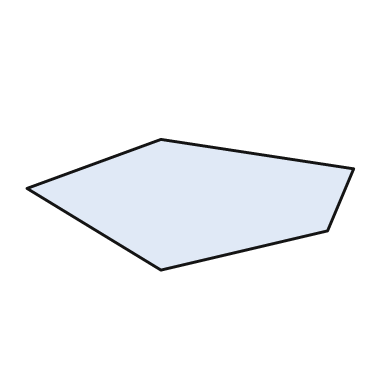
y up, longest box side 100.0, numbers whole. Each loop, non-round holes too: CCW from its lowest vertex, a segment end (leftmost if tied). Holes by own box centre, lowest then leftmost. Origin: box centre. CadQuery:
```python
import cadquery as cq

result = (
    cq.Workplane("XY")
    .moveTo(-9.0, -20.0)
    .lineTo(42.0, -8.0)
    .lineTo(50.0, 11.0)
    .lineTo(-9.0, 20.0)
    .lineTo(-50.0, 5.0)
    .close()
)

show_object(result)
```